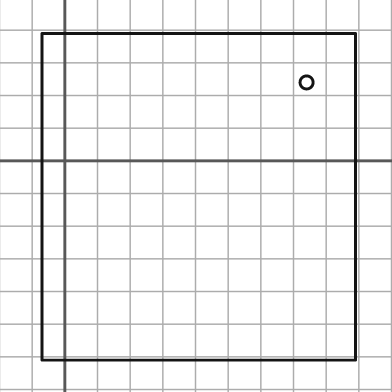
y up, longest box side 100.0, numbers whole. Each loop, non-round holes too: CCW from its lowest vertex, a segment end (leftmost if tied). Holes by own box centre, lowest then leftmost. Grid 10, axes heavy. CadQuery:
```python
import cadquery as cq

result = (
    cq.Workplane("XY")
    .moveTo(-7.0, -61.0)
    .lineTo(89.0, -61.0)
    .lineTo(89.0, 39.0)
    .lineTo(-7.0, 39.0)
    .close()
    .moveTo(74.0, 24.0)
    .circle(2.0)
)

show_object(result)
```